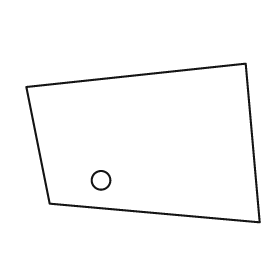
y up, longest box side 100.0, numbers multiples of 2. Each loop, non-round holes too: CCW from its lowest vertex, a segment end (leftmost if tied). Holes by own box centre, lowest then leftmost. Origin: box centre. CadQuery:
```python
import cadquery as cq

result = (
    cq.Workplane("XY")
    .moveTo(50.0, -34.0)
    .lineTo(44.0, 34.0)
    .lineTo(-50.0, 24.0)
    .lineTo(-40.0, -26.0)
    .close()
    .moveTo(-18.0, -16.0)
    .circle(4.0)
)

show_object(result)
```